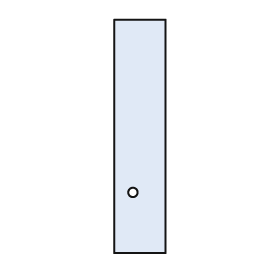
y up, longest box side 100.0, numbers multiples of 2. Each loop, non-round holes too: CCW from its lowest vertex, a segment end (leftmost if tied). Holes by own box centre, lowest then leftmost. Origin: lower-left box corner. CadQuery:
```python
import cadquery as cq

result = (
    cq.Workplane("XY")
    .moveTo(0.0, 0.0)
    .lineTo(22.0, 0.0)
    .lineTo(22.0, 100.0)
    .lineTo(0.0, 100.0)
    .close()
    .moveTo(8.0, 26.0)
    .circle(2.0)
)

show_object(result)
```